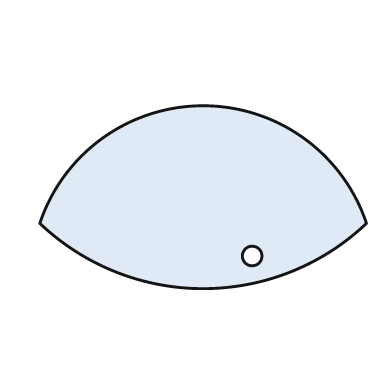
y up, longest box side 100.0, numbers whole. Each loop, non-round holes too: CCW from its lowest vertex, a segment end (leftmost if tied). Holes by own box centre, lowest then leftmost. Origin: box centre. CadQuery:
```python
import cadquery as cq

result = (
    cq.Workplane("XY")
    .moveTo(-50.0, -8.0)
    .threePointArc((0.0, -28.0), (50.0, -8.0))
    .threePointArc((0.0, 28.0), (-50.0, -8.0))
    .close()
    .moveTo(15.0, -18.0)
    .circle(3.0)
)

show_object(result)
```